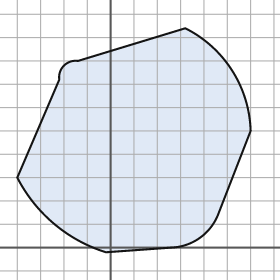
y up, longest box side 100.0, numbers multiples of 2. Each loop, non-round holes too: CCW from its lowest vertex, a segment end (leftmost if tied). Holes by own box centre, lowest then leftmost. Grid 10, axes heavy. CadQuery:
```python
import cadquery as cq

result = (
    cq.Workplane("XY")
    .moveTo(-2.0, -2.0)
    .lineTo(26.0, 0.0)
    .threePointArc((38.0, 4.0), (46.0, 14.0))
    .lineTo(60.0, 50.0)
    .threePointArc((52.0, 76.0), (32.0, 94.0))
    .lineTo(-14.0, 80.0)
    .threePointArc((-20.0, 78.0), (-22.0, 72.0))
    .lineTo(-40.0, 30.0)
    .threePointArc((-24.0, 10.0), (-2.0, -2.0))
    .close()
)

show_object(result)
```